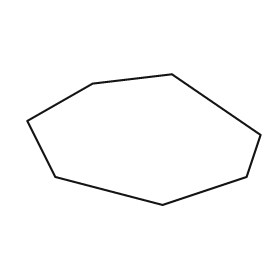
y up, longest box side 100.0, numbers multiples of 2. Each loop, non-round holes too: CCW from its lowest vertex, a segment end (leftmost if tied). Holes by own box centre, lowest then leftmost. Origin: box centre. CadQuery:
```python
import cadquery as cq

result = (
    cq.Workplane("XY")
    .moveTo(8.0, -28.0)
    .lineTo(44.0, -16.0)
    .lineTo(50.0, 2.0)
    .lineTo(12.0, 28.0)
    .lineTo(-22.0, 24.0)
    .lineTo(-50.0, 8.0)
    .lineTo(-38.0, -16.0)
    .close()
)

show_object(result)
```